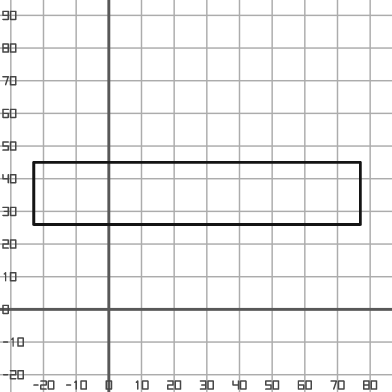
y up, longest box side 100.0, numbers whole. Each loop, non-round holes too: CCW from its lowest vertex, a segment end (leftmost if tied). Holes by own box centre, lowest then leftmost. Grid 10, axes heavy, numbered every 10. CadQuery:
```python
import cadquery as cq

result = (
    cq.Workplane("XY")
    .moveTo(-23.0, 26.0)
    .lineTo(77.0, 26.0)
    .lineTo(77.0, 45.0)
    .lineTo(-23.0, 45.0)
    .close()
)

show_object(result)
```